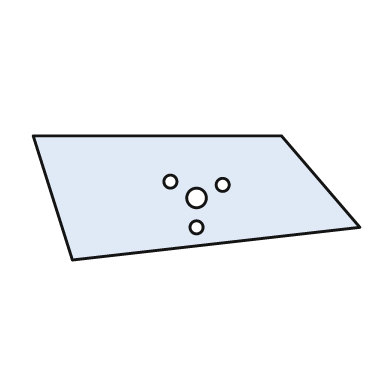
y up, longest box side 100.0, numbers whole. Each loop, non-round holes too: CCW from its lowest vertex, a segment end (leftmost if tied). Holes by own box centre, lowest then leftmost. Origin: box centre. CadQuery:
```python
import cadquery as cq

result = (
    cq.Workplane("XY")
    .moveTo(-38.0, -19.0)
    .lineTo(50.0, -9.0)
    .lineTo(26.0, 19.0)
    .lineTo(-50.0, 19.0)
    .close()
    .moveTo(0.0, -9.0)
    .circle(2.0)
    .moveTo(0.0, 0.0)
    .circle(3.0)
    .moveTo(8.0, 4.0)
    .circle(2.0)
    .moveTo(-8.0, 5.0)
    .circle(2.0)
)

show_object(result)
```